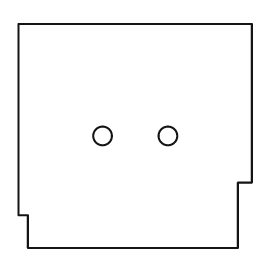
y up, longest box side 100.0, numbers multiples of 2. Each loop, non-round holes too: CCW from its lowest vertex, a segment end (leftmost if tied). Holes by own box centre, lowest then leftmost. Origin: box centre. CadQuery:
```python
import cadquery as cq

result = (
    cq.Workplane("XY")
    .moveTo(-46.0, -48.0)
    .lineTo(44.0, -48.0)
    .lineTo(44.0, -20.0)
    .lineTo(50.0, -20.0)
    .lineTo(50.0, 48.0)
    .lineTo(-50.0, 48.0)
    .lineTo(-50.0, -34.0)
    .lineTo(-46.0, -34.0)
    .close()
    .moveTo(-14.0, 0.0)
    .circle(4.0)
    .moveTo(14.0, 0.0)
    .circle(4.0)
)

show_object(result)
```